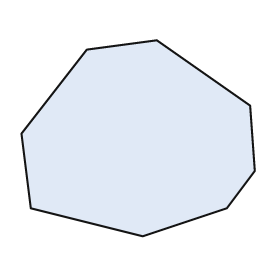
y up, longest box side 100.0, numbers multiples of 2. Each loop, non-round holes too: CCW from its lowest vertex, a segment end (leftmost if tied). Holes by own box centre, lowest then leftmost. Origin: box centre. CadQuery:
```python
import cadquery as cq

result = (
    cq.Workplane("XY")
    .moveTo(2.0, -42.0)
    .lineTo(38.0, -30.0)
    .lineTo(50.0, -14.0)
    .lineTo(48.0, 14.0)
    .lineTo(8.0, 42.0)
    .lineTo(-22.0, 38.0)
    .lineTo(-50.0, 2.0)
    .lineTo(-46.0, -30.0)
    .close()
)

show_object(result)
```